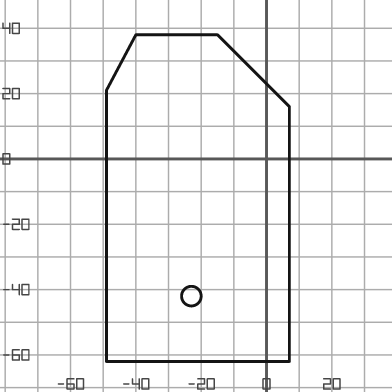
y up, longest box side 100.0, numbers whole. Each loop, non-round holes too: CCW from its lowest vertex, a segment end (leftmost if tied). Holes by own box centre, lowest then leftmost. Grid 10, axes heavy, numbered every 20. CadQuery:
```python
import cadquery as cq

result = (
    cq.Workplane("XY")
    .moveTo(-49.0, -62.0)
    .lineTo(7.0, -62.0)
    .lineTo(7.0, 16.0)
    .lineTo(-15.0, 38.0)
    .lineTo(-40.0, 38.0)
    .lineTo(-49.0, 21.0)
    .close()
    .moveTo(-23.0, -42.0)
    .circle(3.0)
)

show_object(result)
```